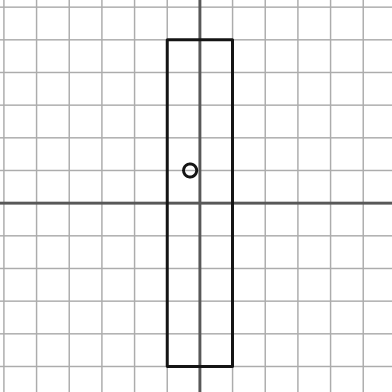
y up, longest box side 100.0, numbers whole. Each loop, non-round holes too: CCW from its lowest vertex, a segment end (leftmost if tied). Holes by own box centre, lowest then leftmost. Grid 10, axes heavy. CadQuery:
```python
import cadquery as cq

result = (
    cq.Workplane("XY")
    .moveTo(-10.0, -50.0)
    .lineTo(10.0, -50.0)
    .lineTo(10.0, 50.0)
    .lineTo(-10.0, 50.0)
    .close()
    .moveTo(-3.0, 10.0)
    .circle(2.0)
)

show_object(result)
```